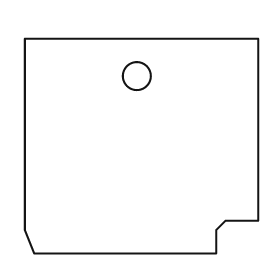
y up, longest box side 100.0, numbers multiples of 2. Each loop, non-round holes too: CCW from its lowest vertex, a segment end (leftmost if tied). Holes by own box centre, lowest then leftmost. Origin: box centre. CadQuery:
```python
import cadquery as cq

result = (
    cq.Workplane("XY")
    .moveTo(-46.0, -46.0)
    .lineTo(32.0, -46.0)
    .lineTo(32.0, -36.0)
    .lineTo(36.0, -32.0)
    .lineTo(50.0, -32.0)
    .lineTo(50.0, 46.0)
    .lineTo(-50.0, 46.0)
    .lineTo(-50.0, -36.0)
    .close()
    .moveTo(-2.0, 30.0)
    .circle(6.0)
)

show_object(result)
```